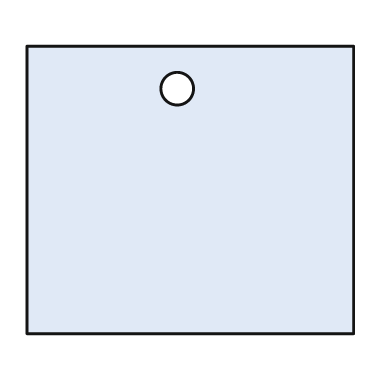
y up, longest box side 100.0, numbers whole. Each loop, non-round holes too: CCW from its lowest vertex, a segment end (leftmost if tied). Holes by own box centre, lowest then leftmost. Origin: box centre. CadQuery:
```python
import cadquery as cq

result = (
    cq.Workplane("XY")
    .moveTo(-50.0, -44.0)
    .lineTo(50.0, -44.0)
    .lineTo(50.0, 44.0)
    .lineTo(-50.0, 44.0)
    .close()
    .moveTo(-4.0, 31.0)
    .circle(5.0)
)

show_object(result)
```